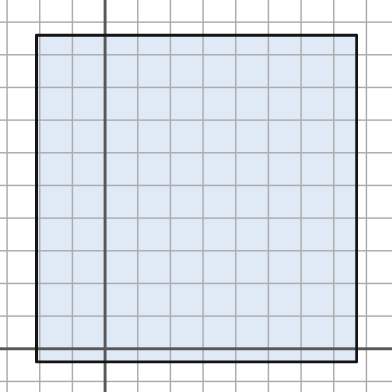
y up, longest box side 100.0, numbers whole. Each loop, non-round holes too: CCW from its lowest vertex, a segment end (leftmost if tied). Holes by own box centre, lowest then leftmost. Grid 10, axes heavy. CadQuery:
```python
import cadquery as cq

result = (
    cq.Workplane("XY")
    .moveTo(-21.0, -4.0)
    .lineTo(77.0, -4.0)
    .lineTo(77.0, 96.0)
    .lineTo(-21.0, 96.0)
    .close()
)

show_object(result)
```